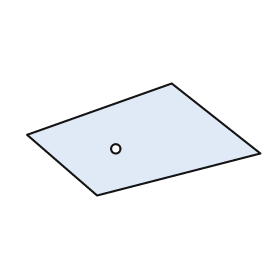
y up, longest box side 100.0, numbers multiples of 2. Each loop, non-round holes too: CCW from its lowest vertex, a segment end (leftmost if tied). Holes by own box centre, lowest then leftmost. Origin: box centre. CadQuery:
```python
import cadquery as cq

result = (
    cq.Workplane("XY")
    .moveTo(-20.0, -24.0)
    .lineTo(50.0, -6.0)
    .lineTo(12.0, 24.0)
    .lineTo(-50.0, 2.0)
    .close()
    .moveTo(-12.0, -4.0)
    .circle(2.0)
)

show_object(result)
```